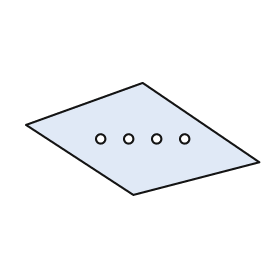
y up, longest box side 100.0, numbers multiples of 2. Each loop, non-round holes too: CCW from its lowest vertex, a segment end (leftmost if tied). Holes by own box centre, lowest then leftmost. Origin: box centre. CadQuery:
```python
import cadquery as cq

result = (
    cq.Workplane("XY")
    .moveTo(-4.0, -24.0)
    .lineTo(50.0, -10.0)
    .lineTo(0.0, 24.0)
    .lineTo(-50.0, 6.0)
    .close()
    .moveTo(-18.0, 0.0)
    .circle(2.0)
    .moveTo(-6.0, 0.0)
    .circle(2.0)
    .moveTo(6.0, 0.0)
    .circle(2.0)
    .moveTo(18.0, 0.0)
    .circle(2.0)
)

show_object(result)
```